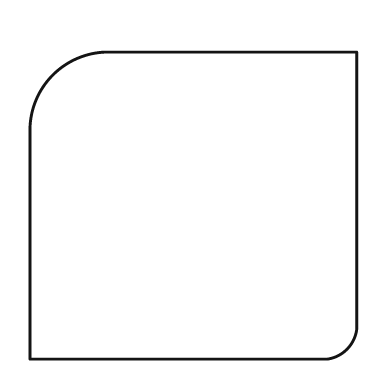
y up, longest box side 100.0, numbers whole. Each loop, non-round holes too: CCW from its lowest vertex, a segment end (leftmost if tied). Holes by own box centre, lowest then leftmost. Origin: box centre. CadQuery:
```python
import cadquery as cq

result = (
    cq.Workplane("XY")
    .moveTo(-50.0, -47.0)
    .lineTo(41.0, -47.0)
    .threePointArc((47.0, -44.0), (50.0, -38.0))
    .lineTo(50.0, 47.0)
    .lineTo(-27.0, 47.0)
    .threePointArc((-43.0, 40.0), (-50.0, 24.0))
    .close()
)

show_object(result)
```